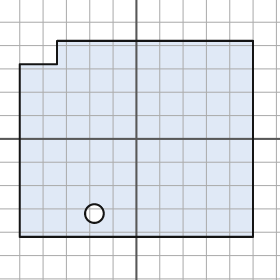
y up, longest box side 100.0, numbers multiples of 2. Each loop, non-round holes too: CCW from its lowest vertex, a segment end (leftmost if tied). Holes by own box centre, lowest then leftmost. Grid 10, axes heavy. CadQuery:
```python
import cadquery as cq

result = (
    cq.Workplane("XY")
    .moveTo(-50.0, -42.0)
    .lineTo(50.0, -42.0)
    .lineTo(50.0, 42.0)
    .lineTo(-34.0, 42.0)
    .lineTo(-34.0, 32.0)
    .lineTo(-50.0, 32.0)
    .close()
    .moveTo(-18.0, -32.0)
    .circle(4.0)
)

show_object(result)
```